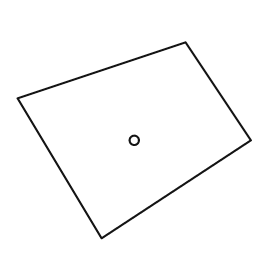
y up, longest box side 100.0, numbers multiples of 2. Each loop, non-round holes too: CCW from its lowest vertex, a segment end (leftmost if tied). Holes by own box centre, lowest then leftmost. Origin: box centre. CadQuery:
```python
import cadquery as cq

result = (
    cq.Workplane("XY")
    .moveTo(-14.0, -42.0)
    .lineTo(50.0, 0.0)
    .lineTo(22.0, 42.0)
    .lineTo(-50.0, 18.0)
    .close()
    .moveTo(0.0, 0.0)
    .circle(2.0)
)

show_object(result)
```